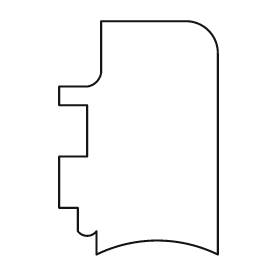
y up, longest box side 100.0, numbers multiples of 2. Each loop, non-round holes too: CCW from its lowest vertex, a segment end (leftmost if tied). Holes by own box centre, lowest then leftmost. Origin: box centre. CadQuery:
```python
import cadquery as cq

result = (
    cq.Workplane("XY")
    .moveTo(-18.0, -50.0)
    .threePointArc((8.0, -44.0), (34.0, -50.0))
    .lineTo(34.0, 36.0)
    .threePointArc((30.0, 46.0), (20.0, 50.0))
    .lineTo(-16.0, 50.0)
    .lineTo(-16.0, 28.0)
    .threePointArc((-18.0, 24.0), (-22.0, 22.0))
    .lineTo(-34.0, 22.0)
    .lineTo(-34.0, 14.0)
    .lineTo(-22.0, 14.0)
    .lineTo(-22.0, -8.0)
    .lineTo(-34.0, -8.0)
    .lineTo(-34.0, -30.0)
    .lineTo(-26.0, -30.0)
    .lineTo(-26.0, -40.0)
    .threePointArc((-22.0, -42.0), (-18.0, -40.0))
    .close()
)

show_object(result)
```